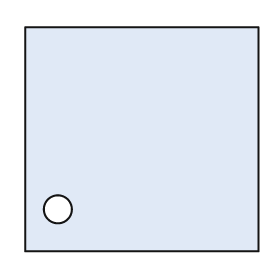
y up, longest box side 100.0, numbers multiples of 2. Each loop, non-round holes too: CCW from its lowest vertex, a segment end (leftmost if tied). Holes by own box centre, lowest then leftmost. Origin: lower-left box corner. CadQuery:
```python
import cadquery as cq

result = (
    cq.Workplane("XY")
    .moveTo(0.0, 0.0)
    .lineTo(100.0, 0.0)
    .lineTo(100.0, 96.0)
    .lineTo(0.0, 96.0)
    .close()
    .moveTo(14.0, 18.0)
    .circle(6.0)
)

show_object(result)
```